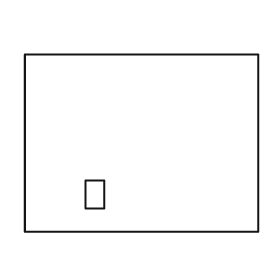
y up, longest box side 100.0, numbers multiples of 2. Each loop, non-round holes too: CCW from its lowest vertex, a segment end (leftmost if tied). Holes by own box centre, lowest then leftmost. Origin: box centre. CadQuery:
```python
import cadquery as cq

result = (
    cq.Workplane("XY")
    .moveTo(-50.0, -38.0)
    .lineTo(50.0, -38.0)
    .lineTo(50.0, 38.0)
    .lineTo(-50.0, 38.0)
    .close()
    .moveTo(-24.0, -28.0)
    .lineTo(-16.0, -28.0)
    .lineTo(-16.0, -16.0)
    .lineTo(-24.0, -16.0)
    .close()
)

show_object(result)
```